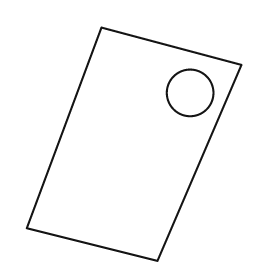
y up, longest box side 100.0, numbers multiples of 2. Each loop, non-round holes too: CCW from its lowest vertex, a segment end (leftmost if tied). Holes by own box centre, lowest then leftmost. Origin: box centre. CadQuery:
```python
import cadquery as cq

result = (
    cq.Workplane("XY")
    .moveTo(10.0, -50.0)
    .lineTo(46.0, 34.0)
    .lineTo(-14.0, 50.0)
    .lineTo(-46.0, -36.0)
    .close()
    .moveTo(24.0, 22.0)
    .circle(10.0)
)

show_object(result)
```